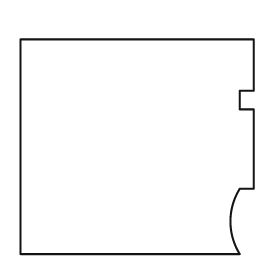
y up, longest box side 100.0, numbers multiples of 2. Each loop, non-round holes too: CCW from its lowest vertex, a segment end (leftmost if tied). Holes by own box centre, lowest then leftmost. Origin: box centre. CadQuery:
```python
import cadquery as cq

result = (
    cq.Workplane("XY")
    .moveTo(-50.0, -46.0)
    .lineTo(44.0, -46.0)
    .threePointArc((40.0, -32.0), (44.0, -18.0))
    .lineTo(50.0, -18.0)
    .lineTo(50.0, 16.0)
    .lineTo(44.0, 16.0)
    .lineTo(44.0, 24.0)
    .lineTo(50.0, 24.0)
    .lineTo(50.0, 46.0)
    .lineTo(-50.0, 46.0)
    .close()
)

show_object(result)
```